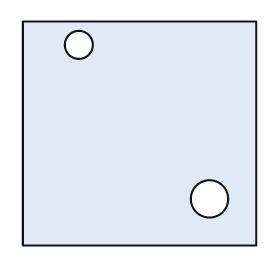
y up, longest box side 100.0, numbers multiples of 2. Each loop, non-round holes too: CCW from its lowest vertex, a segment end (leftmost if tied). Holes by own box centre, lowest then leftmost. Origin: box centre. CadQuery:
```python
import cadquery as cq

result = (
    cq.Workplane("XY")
    .moveTo(-50.0, -48.0)
    .lineTo(50.0, -48.0)
    .lineTo(50.0, 48.0)
    .lineTo(-50.0, 48.0)
    .close()
    .moveTo(30.0, -28.0)
    .circle(8.0)
    .moveTo(-26.0, 38.0)
    .circle(6.0)
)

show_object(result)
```